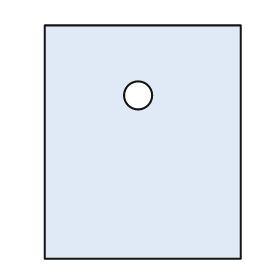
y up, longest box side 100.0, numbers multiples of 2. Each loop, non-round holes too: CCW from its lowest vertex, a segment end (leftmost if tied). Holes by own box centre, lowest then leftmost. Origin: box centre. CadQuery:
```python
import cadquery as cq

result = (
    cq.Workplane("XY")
    .moveTo(-42.0, -50.0)
    .lineTo(42.0, -50.0)
    .lineTo(42.0, 50.0)
    .lineTo(-42.0, 50.0)
    .close()
    .moveTo(-2.0, 20.0)
    .circle(6.0)
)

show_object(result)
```